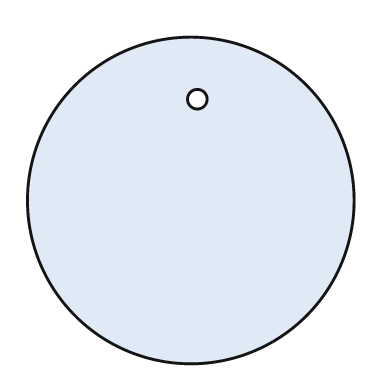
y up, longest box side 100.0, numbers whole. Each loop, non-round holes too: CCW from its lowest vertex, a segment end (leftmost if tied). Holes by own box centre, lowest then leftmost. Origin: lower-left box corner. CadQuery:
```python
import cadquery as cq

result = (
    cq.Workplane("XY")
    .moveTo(50.0, 50.0)
    .circle(50.0)
    .moveTo(52.0, 81.0)
    .circle(3.0)
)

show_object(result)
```